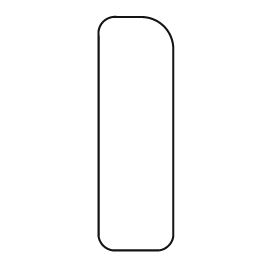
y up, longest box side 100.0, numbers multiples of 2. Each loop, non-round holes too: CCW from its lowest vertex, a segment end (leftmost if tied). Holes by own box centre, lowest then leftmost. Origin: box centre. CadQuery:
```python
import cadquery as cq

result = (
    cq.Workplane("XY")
    .moveTo(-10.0, -50.0)
    .lineTo(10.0, -50.0)
    .threePointArc((14.0, -48.0), (16.0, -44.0))
    .lineTo(16.0, 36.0)
    .threePointArc((12.0, 46.0), (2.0, 50.0))
    .lineTo(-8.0, 50.0)
    .threePointArc((-14.0, 48.0), (-16.0, 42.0))
    .lineTo(-16.0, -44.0)
    .threePointArc((-14.0, -48.0), (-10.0, -50.0))
    .close()
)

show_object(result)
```